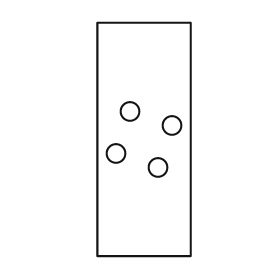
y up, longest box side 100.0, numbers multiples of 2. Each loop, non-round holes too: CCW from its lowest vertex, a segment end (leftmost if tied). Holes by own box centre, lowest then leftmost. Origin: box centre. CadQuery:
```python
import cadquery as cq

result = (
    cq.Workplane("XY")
    .moveTo(-20.0, -50.0)
    .lineTo(20.0, -50.0)
    .lineTo(20.0, 50.0)
    .lineTo(-20.0, 50.0)
    .close()
    .moveTo(6.0, -12.0)
    .circle(4.0)
    .moveTo(-12.0, -6.0)
    .circle(4.0)
    .moveTo(12.0, 6.0)
    .circle(4.0)
    .moveTo(-6.0, 12.0)
    .circle(4.0)
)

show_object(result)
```